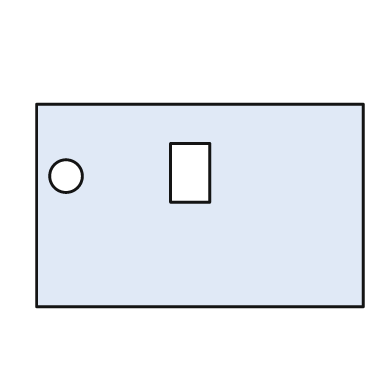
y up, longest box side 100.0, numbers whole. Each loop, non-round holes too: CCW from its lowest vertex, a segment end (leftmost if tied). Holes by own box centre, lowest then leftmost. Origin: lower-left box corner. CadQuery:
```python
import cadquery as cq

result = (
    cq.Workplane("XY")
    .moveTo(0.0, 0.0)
    .lineTo(100.0, 0.0)
    .lineTo(100.0, 62.0)
    .lineTo(0.0, 62.0)
    .close()
    .moveTo(9.0, 40.0)
    .circle(5.0)
    .moveTo(41.0, 32.0)
    .lineTo(53.0, 32.0)
    .lineTo(53.0, 50.0)
    .lineTo(41.0, 50.0)
    .close()
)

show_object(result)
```